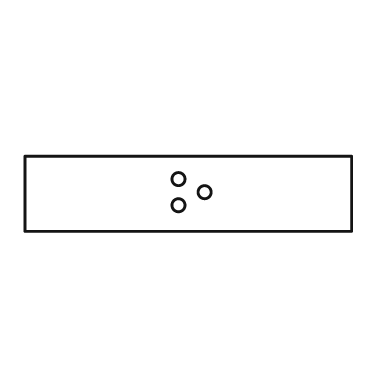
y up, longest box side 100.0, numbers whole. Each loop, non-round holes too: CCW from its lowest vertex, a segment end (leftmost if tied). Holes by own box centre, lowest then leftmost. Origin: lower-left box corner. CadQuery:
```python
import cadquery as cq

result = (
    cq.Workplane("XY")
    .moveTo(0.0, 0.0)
    .lineTo(100.0, 0.0)
    .lineTo(100.0, 23.0)
    .lineTo(0.0, 23.0)
    .close()
    .moveTo(47.0, 8.0)
    .circle(2.0)
    .moveTo(55.0, 12.0)
    .circle(2.0)
    .moveTo(47.0, 16.0)
    .circle(2.0)
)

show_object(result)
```